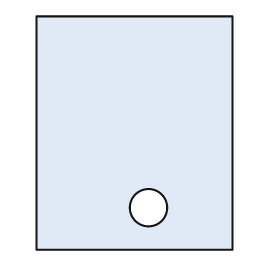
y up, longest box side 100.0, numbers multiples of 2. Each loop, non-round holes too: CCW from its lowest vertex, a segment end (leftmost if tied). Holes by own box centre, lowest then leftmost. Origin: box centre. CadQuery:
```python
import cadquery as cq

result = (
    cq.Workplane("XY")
    .moveTo(-42.0, -50.0)
    .lineTo(42.0, -50.0)
    .lineTo(42.0, 50.0)
    .lineTo(-42.0, 50.0)
    .close()
    .moveTo(6.0, -32.0)
    .circle(8.0)
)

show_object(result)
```